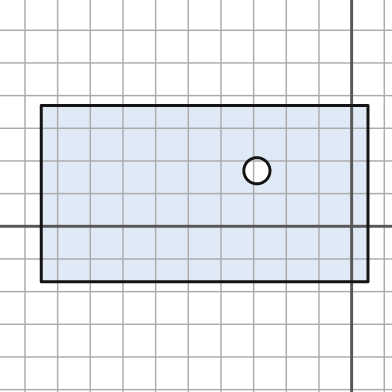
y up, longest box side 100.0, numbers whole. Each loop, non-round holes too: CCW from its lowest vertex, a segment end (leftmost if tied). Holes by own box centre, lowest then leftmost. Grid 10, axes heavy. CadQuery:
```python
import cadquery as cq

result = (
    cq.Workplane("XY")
    .moveTo(-95.0, -17.0)
    .lineTo(5.0, -17.0)
    .lineTo(5.0, 37.0)
    .lineTo(-95.0, 37.0)
    .close()
    .moveTo(-29.0, 17.0)
    .circle(4.0)
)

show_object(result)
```